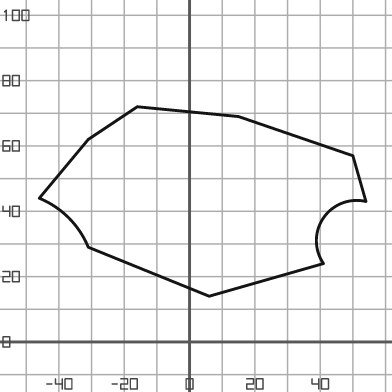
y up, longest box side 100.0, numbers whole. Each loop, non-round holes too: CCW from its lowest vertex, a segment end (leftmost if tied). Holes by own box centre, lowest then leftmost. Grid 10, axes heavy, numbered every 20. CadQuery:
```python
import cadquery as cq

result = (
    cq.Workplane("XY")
    .moveTo(6.0, 14.0)
    .lineTo(41.0, 24.0)
    .threePointArc((41.0, 38.0), (54.0, 43.0))
    .lineTo(50.0, 57.0)
    .lineTo(15.0, 69.0)
    .lineTo(-16.0, 72.0)
    .lineTo(-31.0, 62.0)
    .lineTo(-46.0, 44.0)
    .threePointArc((-37.0, 38.0), (-31.0, 29.0))
    .close()
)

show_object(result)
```